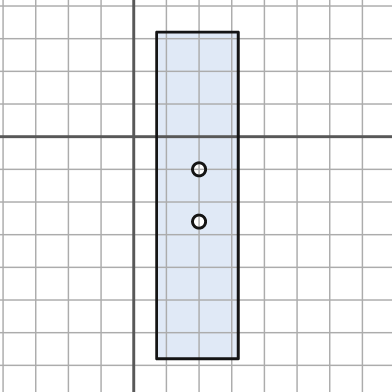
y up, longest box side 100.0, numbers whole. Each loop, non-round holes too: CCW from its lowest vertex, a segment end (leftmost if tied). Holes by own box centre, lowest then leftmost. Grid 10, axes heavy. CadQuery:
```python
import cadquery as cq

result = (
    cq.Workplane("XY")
    .moveTo(7.0, -68.0)
    .lineTo(32.0, -68.0)
    .lineTo(32.0, 32.0)
    .lineTo(7.0, 32.0)
    .close()
    .moveTo(20.0, -26.0)
    .circle(2.0)
    .moveTo(20.0, -10.0)
    .circle(2.0)
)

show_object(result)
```